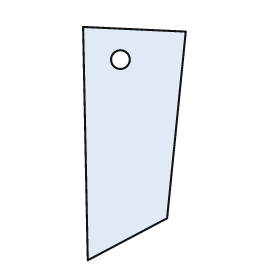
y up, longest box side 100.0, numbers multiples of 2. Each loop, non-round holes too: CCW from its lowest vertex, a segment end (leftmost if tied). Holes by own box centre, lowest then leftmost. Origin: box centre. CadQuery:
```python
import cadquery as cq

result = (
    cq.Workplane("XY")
    .moveTo(-20.0, -50.0)
    .lineTo(14.0, -32.0)
    .lineTo(22.0, 48.0)
    .lineTo(-22.0, 50.0)
    .close()
    .moveTo(-6.0, 36.0)
    .circle(4.0)
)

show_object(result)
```